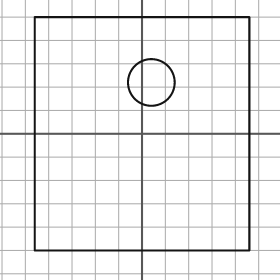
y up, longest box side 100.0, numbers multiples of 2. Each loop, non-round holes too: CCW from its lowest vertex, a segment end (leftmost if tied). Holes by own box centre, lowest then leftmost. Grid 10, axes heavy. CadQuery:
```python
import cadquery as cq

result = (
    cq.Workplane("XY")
    .moveTo(-46.0, -50.0)
    .lineTo(46.0, -50.0)
    .lineTo(46.0, 50.0)
    .lineTo(-46.0, 50.0)
    .close()
    .moveTo(4.0, 22.0)
    .circle(10.0)
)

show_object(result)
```